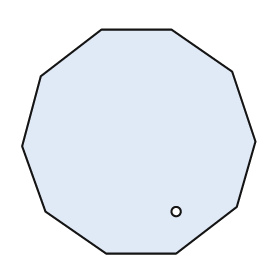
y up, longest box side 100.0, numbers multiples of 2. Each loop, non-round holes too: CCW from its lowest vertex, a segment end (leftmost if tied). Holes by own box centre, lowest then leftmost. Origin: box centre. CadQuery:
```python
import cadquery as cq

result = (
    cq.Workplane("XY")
    .moveTo(-14.0, -48.0)
    .lineTo(16.0, -48.0)
    .lineTo(42.0, -28.0)
    .lineTo(50.0, 0.0)
    .lineTo(40.0, 30.0)
    .lineTo(14.0, 48.0)
    .lineTo(-16.0, 48.0)
    .lineTo(-42.0, 28.0)
    .lineTo(-50.0, -2.0)
    .lineTo(-40.0, -30.0)
    .close()
    .moveTo(16.0, -30.0)
    .circle(2.0)
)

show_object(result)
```